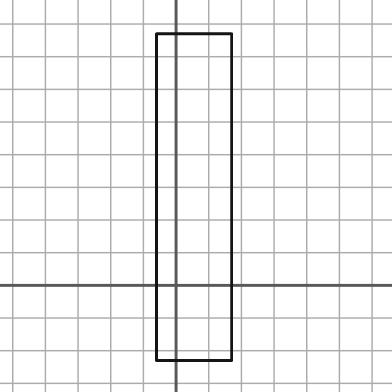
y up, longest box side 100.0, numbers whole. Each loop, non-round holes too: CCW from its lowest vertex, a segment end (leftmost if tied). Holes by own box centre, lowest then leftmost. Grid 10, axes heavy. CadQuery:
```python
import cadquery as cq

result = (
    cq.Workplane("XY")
    .moveTo(-6.0, -23.0)
    .lineTo(17.0, -23.0)
    .lineTo(17.0, 77.0)
    .lineTo(-6.0, 77.0)
    .close()
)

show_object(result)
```